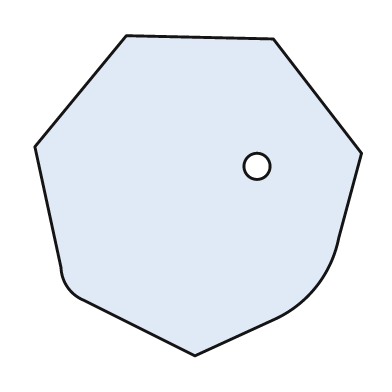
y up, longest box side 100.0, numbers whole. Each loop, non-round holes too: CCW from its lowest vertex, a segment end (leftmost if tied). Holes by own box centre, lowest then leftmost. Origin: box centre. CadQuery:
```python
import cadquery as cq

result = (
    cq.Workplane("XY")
    .moveTo(-1.0, -49.0)
    .lineTo(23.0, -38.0)
    .threePointArc((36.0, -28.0), (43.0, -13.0))
    .lineTo(50.0, 13.0)
    .lineTo(23.0, 48.0)
    .lineTo(-22.0, 49.0)
    .lineTo(-50.0, 15.0)
    .lineTo(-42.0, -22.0)
    .threePointArc((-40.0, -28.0), (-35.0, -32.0))
    .close()
    .moveTo(18.0, 9.0)
    .circle(4.0)
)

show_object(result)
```